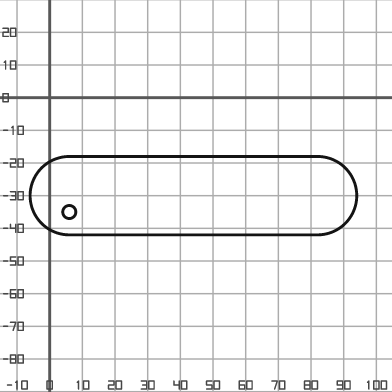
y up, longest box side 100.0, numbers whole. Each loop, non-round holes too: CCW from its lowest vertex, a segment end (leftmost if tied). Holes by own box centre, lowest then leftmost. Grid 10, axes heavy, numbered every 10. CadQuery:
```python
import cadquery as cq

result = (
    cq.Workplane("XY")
    .moveTo(6.0, -42.0)
    .lineTo(82.0, -42.0)
    .threePointArc((94.0, -30.0), (82.0, -18.0))
    .lineTo(6.0, -18.0)
    .threePointArc((-6.0, -30.0), (6.0, -42.0))
    .close()
    .moveTo(6.0, -35.0)
    .circle(2.0)
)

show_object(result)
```